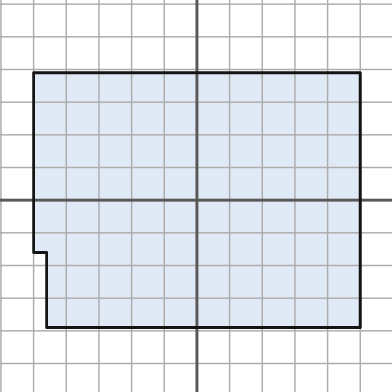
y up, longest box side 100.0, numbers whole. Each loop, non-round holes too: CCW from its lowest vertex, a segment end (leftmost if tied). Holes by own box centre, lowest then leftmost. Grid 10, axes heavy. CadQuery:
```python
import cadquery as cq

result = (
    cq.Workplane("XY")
    .moveTo(-46.0, -39.0)
    .lineTo(50.0, -39.0)
    .lineTo(50.0, 39.0)
    .lineTo(-50.0, 39.0)
    .lineTo(-50.0, -16.0)
    .lineTo(-46.0, -16.0)
    .close()
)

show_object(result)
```